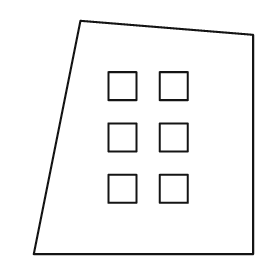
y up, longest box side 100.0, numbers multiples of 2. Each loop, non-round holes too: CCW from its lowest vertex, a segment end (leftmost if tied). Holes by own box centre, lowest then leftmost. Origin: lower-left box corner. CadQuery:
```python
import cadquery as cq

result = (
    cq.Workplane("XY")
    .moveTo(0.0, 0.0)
    .lineTo(94.0, 0.0)
    .lineTo(94.0, 94.0)
    .lineTo(20.0, 100.0)
    .close()
    .moveTo(32.0, 22.0)
    .lineTo(44.0, 22.0)
    .lineTo(44.0, 34.0)
    .lineTo(32.0, 34.0)
    .close()
    .moveTo(54.0, 22.0)
    .lineTo(66.0, 22.0)
    .lineTo(66.0, 34.0)
    .lineTo(54.0, 34.0)
    .close()
    .moveTo(32.0, 44.0)
    .lineTo(44.0, 44.0)
    .lineTo(44.0, 56.0)
    .lineTo(32.0, 56.0)
    .close()
    .moveTo(54.0, 44.0)
    .lineTo(66.0, 44.0)
    .lineTo(66.0, 56.0)
    .lineTo(54.0, 56.0)
    .close()
    .moveTo(32.0, 66.0)
    .lineTo(44.0, 66.0)
    .lineTo(44.0, 78.0)
    .lineTo(32.0, 78.0)
    .close()
    .moveTo(54.0, 66.0)
    .lineTo(66.0, 66.0)
    .lineTo(66.0, 78.0)
    .lineTo(54.0, 78.0)
    .close()
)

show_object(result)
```